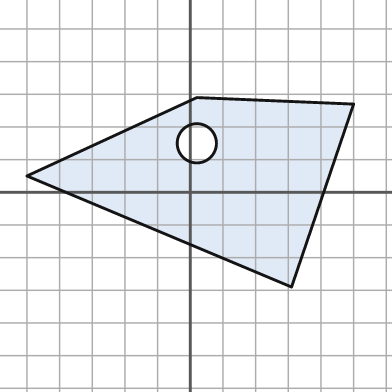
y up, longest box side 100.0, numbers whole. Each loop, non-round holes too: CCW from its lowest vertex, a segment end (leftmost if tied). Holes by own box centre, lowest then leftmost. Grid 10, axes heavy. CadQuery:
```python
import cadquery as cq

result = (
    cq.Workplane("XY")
    .moveTo(31.0, -29.0)
    .lineTo(50.0, 27.0)
    .lineTo(2.0, 29.0)
    .lineTo(-50.0, 5.0)
    .close()
    .moveTo(2.0, 15.0)
    .circle(6.0)
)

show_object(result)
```